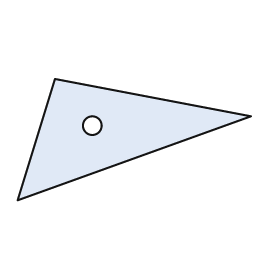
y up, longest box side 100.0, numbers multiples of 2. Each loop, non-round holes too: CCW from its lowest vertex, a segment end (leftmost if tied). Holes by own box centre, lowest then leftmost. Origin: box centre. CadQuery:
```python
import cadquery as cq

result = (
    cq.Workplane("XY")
    .moveTo(-50.0, -26.0)
    .lineTo(50.0, 10.0)
    .lineTo(-34.0, 26.0)
    .close()
    .moveTo(-18.0, 6.0)
    .circle(4.0)
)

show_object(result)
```